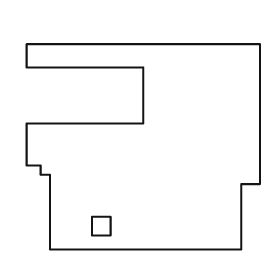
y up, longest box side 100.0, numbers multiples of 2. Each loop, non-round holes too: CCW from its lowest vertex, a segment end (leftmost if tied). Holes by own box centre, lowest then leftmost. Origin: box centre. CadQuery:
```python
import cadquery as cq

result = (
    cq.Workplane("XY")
    .moveTo(-40.0, -44.0)
    .lineTo(42.0, -44.0)
    .lineTo(42.0, -16.0)
    .lineTo(50.0, -16.0)
    .lineTo(50.0, 44.0)
    .lineTo(-50.0, 44.0)
    .lineTo(-50.0, 34.0)
    .lineTo(0.0, 34.0)
    .lineTo(0.0, 10.0)
    .lineTo(-50.0, 10.0)
    .lineTo(-50.0, -8.0)
    .lineTo(-44.0, -8.0)
    .lineTo(-44.0, -12.0)
    .lineTo(-40.0, -12.0)
    .close()
    .moveTo(-22.0, -38.0)
    .lineTo(-14.0, -38.0)
    .lineTo(-14.0, -30.0)
    .lineTo(-22.0, -30.0)
    .close()
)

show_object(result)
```